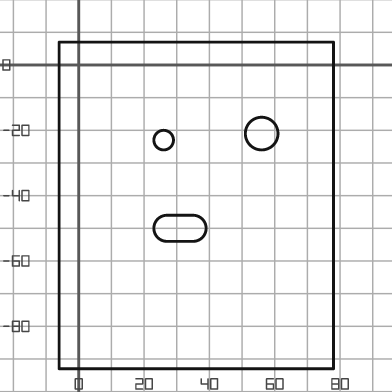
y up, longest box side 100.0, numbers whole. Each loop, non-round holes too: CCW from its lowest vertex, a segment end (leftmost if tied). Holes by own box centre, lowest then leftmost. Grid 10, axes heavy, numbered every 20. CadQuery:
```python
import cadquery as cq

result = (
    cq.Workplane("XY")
    .moveTo(-6.0, -93.0)
    .lineTo(78.0, -93.0)
    .lineTo(78.0, 7.0)
    .lineTo(-6.0, 7.0)
    .close()
    .moveTo(27.0, -54.0)
    .lineTo(35.0, -54.0)
    .threePointArc((39.0, -50.0), (35.0, -46.0))
    .lineTo(27.0, -46.0)
    .threePointArc((23.0, -50.0), (27.0, -54.0))
    .close()
    .moveTo(26.0, -23.0)
    .circle(3.0)
    .moveTo(56.0, -21.0)
    .circle(5.0)
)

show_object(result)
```